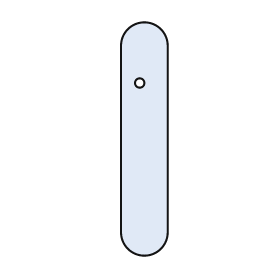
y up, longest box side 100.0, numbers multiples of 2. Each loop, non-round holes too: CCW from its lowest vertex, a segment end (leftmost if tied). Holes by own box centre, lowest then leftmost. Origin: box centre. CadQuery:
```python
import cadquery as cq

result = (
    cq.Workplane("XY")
    .moveTo(-10.0, -40.0)
    .threePointArc((0.0, -50.0), (10.0, -40.0))
    .lineTo(10.0, 40.0)
    .threePointArc((0.0, 50.0), (-10.0, 40.0))
    .close()
    .moveTo(-2.0, 24.0)
    .circle(2.0)
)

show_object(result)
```